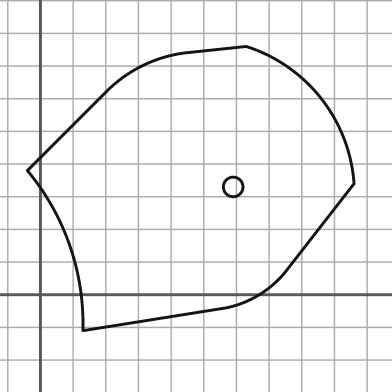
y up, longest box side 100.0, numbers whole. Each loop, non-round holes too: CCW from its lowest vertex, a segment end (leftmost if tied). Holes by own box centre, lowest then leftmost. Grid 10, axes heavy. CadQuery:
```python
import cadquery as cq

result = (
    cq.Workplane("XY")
    .moveTo(13.0, -11.0)
    .lineTo(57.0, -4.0)
    .threePointArc((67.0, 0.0), (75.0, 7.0))
    .lineTo(96.0, 34.0)
    .threePointArc((86.0, 60.0), (63.0, 76.0))
    .lineTo(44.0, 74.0)
    .threePointArc((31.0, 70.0), (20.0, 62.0))
    .lineTo(-4.0, 38.0)
    .threePointArc((9.0, 15.0), (13.0, -11.0))
    .close()
    .moveTo(59.0, 33.0)
    .circle(3.0)
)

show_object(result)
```